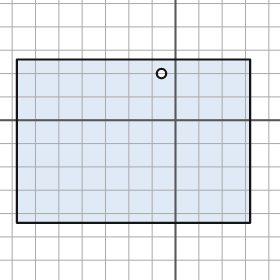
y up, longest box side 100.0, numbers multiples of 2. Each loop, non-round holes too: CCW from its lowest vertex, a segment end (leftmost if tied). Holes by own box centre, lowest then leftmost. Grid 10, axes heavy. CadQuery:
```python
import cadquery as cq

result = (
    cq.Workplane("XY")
    .moveTo(-68.0, -44.0)
    .lineTo(32.0, -44.0)
    .lineTo(32.0, 26.0)
    .lineTo(-68.0, 26.0)
    .close()
    .moveTo(-6.0, 20.0)
    .circle(2.0)
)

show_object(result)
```